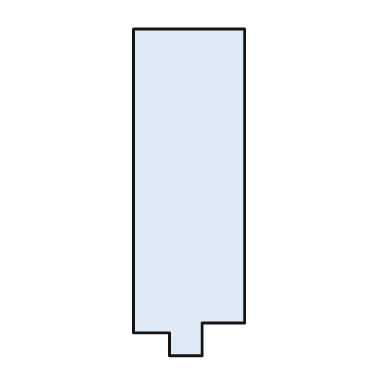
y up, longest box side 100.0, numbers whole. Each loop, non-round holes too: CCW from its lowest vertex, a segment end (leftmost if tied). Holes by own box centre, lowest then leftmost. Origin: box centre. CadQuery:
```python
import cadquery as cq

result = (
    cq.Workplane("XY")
    .moveTo(-6.0, -50.0)
    .lineTo(4.0, -50.0)
    .lineTo(4.0, -40.0)
    .lineTo(17.0, -40.0)
    .lineTo(17.0, 50.0)
    .lineTo(-17.0, 50.0)
    .lineTo(-17.0, -43.0)
    .lineTo(-6.0, -43.0)
    .close()
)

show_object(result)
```